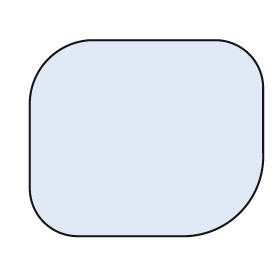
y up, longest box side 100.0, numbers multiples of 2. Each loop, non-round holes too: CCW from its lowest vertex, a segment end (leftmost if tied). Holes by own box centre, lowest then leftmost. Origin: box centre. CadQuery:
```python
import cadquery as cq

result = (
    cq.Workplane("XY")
    .moveTo(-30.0, -42.0)
    .lineTo(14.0, -42.0)
    .threePointArc((40.0, -32.0), (50.0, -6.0))
    .lineTo(50.0, 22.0)
    .threePointArc((44.0, 36.0), (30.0, 42.0))
    .lineTo(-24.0, 42.0)
    .threePointArc((-42.0, 34.0), (-50.0, 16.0))
    .lineTo(-50.0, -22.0)
    .threePointArc((-44.0, -36.0), (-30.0, -42.0))
    .close()
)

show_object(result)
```